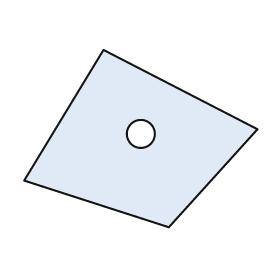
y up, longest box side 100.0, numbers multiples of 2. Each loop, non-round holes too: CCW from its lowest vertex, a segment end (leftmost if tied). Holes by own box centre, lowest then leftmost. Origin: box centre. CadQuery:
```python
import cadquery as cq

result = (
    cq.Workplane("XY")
    .moveTo(12.0, -38.0)
    .lineTo(50.0, 4.0)
    .lineTo(-16.0, 38.0)
    .lineTo(-50.0, -18.0)
    .close()
    .moveTo(0.0, 2.0)
    .circle(6.0)
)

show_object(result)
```